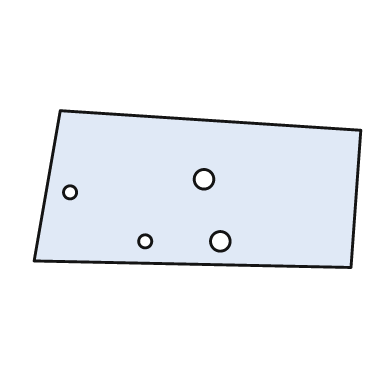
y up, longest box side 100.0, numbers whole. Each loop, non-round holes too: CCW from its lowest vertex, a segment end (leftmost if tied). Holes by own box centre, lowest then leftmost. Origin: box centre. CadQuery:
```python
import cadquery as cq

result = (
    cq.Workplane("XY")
    .moveTo(47.0, -24.0)
    .lineTo(50.0, 18.0)
    .lineTo(-42.0, 24.0)
    .lineTo(-50.0, -22.0)
    .close()
    .moveTo(-16.0, -16.0)
    .circle(2.0)
    .moveTo(7.0, -16.0)
    .circle(3.0)
    .moveTo(-39.0, -1.0)
    .circle(2.0)
    .moveTo(2.0, 3.0)
    .circle(3.0)
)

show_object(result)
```